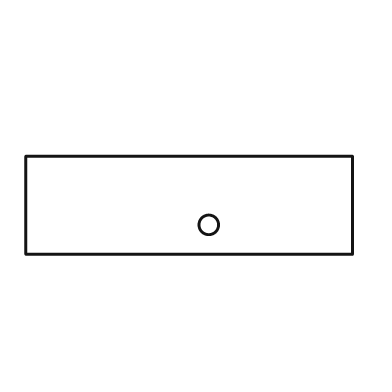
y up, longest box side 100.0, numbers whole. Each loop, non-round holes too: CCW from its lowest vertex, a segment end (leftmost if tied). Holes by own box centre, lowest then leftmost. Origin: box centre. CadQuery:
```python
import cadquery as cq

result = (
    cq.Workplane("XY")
    .moveTo(-50.0, -15.0)
    .lineTo(50.0, -15.0)
    .lineTo(50.0, 15.0)
    .lineTo(-50.0, 15.0)
    .close()
    .moveTo(6.0, -6.0)
    .circle(3.0)
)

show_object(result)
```